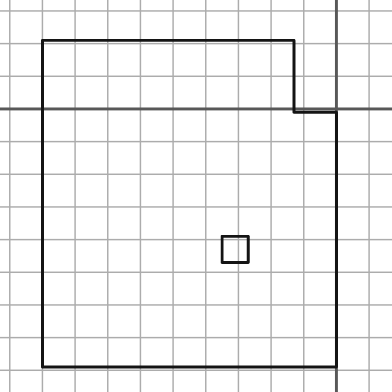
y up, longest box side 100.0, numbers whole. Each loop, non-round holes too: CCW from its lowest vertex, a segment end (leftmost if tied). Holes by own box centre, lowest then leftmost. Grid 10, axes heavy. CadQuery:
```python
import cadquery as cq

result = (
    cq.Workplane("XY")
    .moveTo(-90.0, -79.0)
    .lineTo(0.0, -79.0)
    .lineTo(0.0, -1.0)
    .lineTo(-13.0, -1.0)
    .lineTo(-13.0, 21.0)
    .lineTo(-90.0, 21.0)
    .close()
    .moveTo(-35.0, -47.0)
    .lineTo(-27.0, -47.0)
    .lineTo(-27.0, -39.0)
    .lineTo(-35.0, -39.0)
    .close()
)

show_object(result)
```